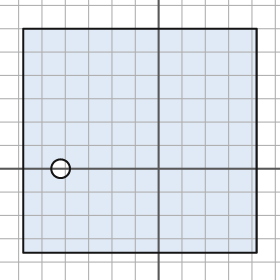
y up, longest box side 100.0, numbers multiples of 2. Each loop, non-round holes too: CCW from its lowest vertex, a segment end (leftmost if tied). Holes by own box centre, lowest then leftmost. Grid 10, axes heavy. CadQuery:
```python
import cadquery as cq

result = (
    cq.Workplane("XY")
    .moveTo(-58.0, -36.0)
    .lineTo(42.0, -36.0)
    .lineTo(42.0, 60.0)
    .lineTo(-58.0, 60.0)
    .close()
    .moveTo(-42.0, 0.0)
    .circle(4.0)
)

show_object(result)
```